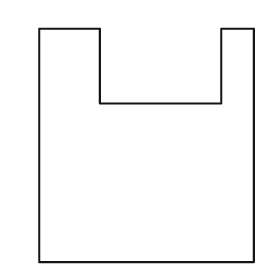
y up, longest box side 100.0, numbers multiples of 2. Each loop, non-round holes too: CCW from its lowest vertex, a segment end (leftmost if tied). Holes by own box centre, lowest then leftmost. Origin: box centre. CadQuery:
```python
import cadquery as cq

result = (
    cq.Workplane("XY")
    .moveTo(-46.0, -50.0)
    .lineTo(46.0, -50.0)
    .lineTo(46.0, 50.0)
    .lineTo(32.0, 50.0)
    .lineTo(32.0, 18.0)
    .lineTo(-20.0, 18.0)
    .lineTo(-20.0, 50.0)
    .lineTo(-46.0, 50.0)
    .close()
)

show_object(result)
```